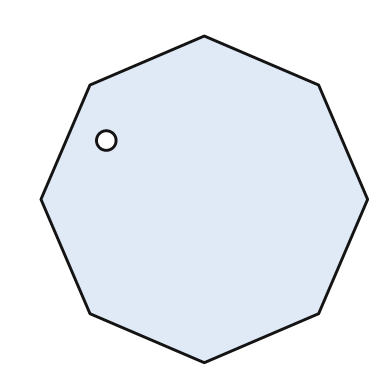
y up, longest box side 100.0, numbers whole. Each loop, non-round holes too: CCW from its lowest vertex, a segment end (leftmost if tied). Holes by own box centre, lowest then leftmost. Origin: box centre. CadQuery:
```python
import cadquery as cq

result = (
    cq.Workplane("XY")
    .moveTo(0.0, -50.0)
    .lineTo(35.0, -35.0)
    .lineTo(50.0, 0.0)
    .lineTo(35.0, 35.0)
    .lineTo(0.0, 50.0)
    .lineTo(-35.0, 35.0)
    .lineTo(-50.0, 0.0)
    .lineTo(-35.0, -35.0)
    .close()
    .moveTo(-30.0, 18.0)
    .circle(3.0)
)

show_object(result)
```